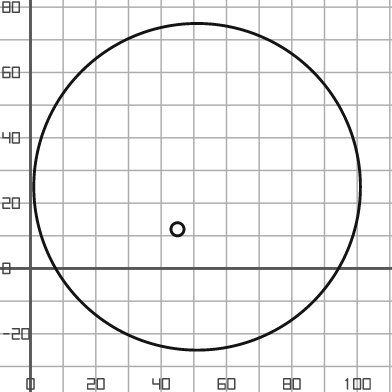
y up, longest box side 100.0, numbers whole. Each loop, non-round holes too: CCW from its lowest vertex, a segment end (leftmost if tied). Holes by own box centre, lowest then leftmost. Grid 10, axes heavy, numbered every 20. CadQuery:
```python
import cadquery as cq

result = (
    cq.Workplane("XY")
    .moveTo(51.0, 25.0)
    .circle(50.0)
    .moveTo(45.0, 12.0)
    .circle(2.0)
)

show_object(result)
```